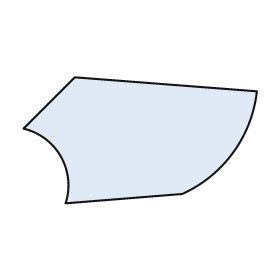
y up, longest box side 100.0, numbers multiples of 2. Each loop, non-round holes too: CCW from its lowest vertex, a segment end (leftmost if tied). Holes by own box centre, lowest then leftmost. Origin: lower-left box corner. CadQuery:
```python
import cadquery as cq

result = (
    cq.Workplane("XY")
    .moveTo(18.0, 0.0)
    .lineTo(68.0, 4.0)
    .threePointArc((90.0, 22.0), (100.0, 48.0))
    .lineTo(22.0, 54.0)
    .lineTo(0.0, 32.0)
    .threePointArc((16.0, 20.0), (18.0, 0.0))
    .close()
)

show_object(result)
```